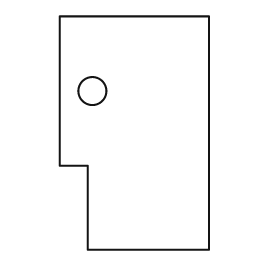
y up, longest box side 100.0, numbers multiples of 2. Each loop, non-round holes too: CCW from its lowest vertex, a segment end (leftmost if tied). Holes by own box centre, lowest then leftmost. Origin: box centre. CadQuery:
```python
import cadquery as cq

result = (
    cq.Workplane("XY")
    .moveTo(-20.0, -50.0)
    .lineTo(32.0, -50.0)
    .lineTo(32.0, 50.0)
    .lineTo(-32.0, 50.0)
    .lineTo(-32.0, -14.0)
    .lineTo(-20.0, -14.0)
    .close()
    .moveTo(-18.0, 18.0)
    .circle(6.0)
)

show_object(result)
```